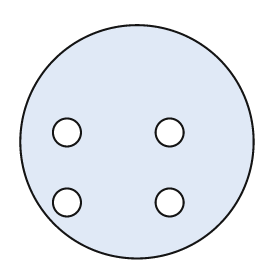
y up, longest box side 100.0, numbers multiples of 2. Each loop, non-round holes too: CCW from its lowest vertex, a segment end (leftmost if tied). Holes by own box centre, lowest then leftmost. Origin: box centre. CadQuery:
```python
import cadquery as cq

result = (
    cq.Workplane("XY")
    .moveTo(0.0, 0.0)
    .circle(50.0)
    .moveTo(-30.0, -26.0)
    .circle(6.0)
    .moveTo(14.0, -26.0)
    .circle(6.0)
    .moveTo(-30.0, 4.0)
    .circle(6.0)
    .moveTo(14.0, 4.0)
    .circle(6.0)
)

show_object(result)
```